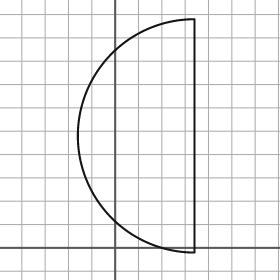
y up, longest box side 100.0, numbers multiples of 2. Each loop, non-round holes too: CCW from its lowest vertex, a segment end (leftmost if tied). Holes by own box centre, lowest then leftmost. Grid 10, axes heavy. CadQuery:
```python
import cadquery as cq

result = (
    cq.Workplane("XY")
    .moveTo(34.0, -2.0)
    .lineTo(34.0, 98.0)
    .threePointArc((-16.0, 48.0), (34.0, -2.0))
    .close()
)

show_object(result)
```